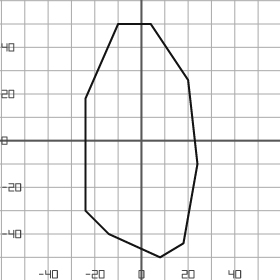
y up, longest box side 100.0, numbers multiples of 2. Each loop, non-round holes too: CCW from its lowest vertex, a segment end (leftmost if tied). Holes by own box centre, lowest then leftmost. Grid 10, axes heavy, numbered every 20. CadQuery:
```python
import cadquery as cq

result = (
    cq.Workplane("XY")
    .moveTo(8.0, -50.0)
    .lineTo(18.0, -44.0)
    .lineTo(24.0, -10.0)
    .lineTo(20.0, 26.0)
    .lineTo(4.0, 50.0)
    .lineTo(-10.0, 50.0)
    .lineTo(-24.0, 18.0)
    .lineTo(-24.0, -30.0)
    .lineTo(-14.0, -40.0)
    .close()
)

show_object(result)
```